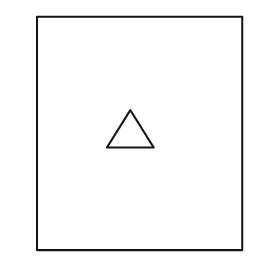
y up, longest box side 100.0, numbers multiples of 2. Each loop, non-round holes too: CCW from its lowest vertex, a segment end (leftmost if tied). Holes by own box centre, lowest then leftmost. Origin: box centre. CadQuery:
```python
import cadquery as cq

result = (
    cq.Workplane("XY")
    .moveTo(-44.0, -50.0)
    .lineTo(44.0, -50.0)
    .lineTo(44.0, 50.0)
    .lineTo(-44.0, 50.0)
    .close()
    .moveTo(-14.0, -6.0)
    .lineTo(6.0, -6.0)
    .lineTo(-4.0, 10.0)
    .close()
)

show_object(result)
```